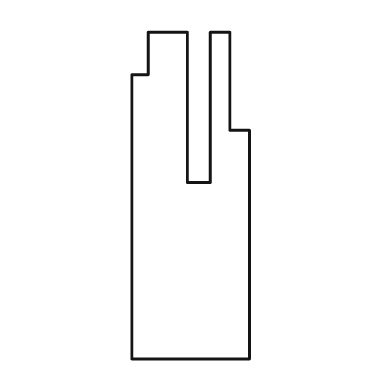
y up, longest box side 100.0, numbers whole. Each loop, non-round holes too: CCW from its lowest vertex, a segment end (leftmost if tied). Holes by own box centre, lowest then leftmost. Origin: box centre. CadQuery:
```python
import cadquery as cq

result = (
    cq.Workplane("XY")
    .moveTo(-18.0, -50.0)
    .lineTo(18.0, -50.0)
    .lineTo(18.0, 20.0)
    .lineTo(12.0, 20.0)
    .lineTo(12.0, 50.0)
    .lineTo(6.0, 50.0)
    .lineTo(6.0, 4.0)
    .lineTo(-1.0, 4.0)
    .lineTo(-1.0, 50.0)
    .lineTo(-13.0, 50.0)
    .lineTo(-13.0, 37.0)
    .lineTo(-18.0, 37.0)
    .close()
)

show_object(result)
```